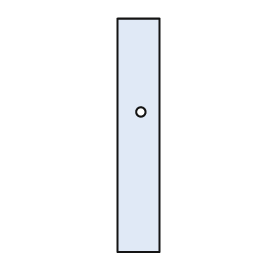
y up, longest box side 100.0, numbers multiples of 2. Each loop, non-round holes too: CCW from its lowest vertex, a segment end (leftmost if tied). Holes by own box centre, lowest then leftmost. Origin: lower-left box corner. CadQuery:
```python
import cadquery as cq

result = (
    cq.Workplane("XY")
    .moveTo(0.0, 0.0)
    .lineTo(18.0, 0.0)
    .lineTo(18.0, 100.0)
    .lineTo(0.0, 100.0)
    .close()
    .moveTo(10.0, 60.0)
    .circle(2.0)
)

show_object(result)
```